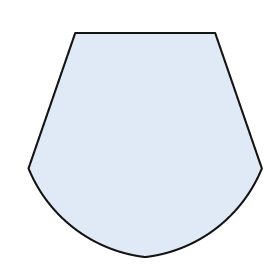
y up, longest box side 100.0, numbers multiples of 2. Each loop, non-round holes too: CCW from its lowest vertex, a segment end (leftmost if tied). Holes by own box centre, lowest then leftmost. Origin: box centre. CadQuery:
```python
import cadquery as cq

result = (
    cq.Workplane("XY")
    .moveTo(0.0, -48.0)
    .threePointArc((30.0, -36.0), (50.0, -10.0))
    .lineTo(30.0, 48.0)
    .lineTo(-30.0, 48.0)
    .lineTo(-50.0, -10.0)
    .threePointArc((-30.0, -36.0), (0.0, -48.0))
    .close()
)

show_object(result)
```